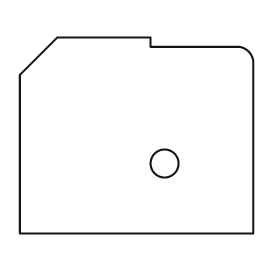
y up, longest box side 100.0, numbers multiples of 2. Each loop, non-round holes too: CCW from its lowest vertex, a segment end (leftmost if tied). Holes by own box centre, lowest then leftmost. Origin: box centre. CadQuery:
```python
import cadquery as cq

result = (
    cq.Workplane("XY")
    .moveTo(-50.0, -42.0)
    .lineTo(50.0, -42.0)
    .lineTo(50.0, 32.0)
    .threePointArc((48.0, 36.0), (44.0, 38.0))
    .lineTo(6.0, 38.0)
    .lineTo(6.0, 42.0)
    .lineTo(-34.0, 42.0)
    .lineTo(-50.0, 26.0)
    .close()
    .moveTo(12.0, -12.0)
    .circle(6.0)
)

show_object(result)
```